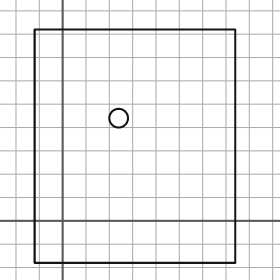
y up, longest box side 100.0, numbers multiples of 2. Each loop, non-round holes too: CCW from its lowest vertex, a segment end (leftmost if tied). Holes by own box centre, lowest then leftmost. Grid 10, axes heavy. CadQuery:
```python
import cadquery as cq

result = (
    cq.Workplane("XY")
    .moveTo(-12.0, -18.0)
    .lineTo(74.0, -18.0)
    .lineTo(74.0, 82.0)
    .lineTo(-12.0, 82.0)
    .close()
    .moveTo(24.0, 44.0)
    .circle(4.0)
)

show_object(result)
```